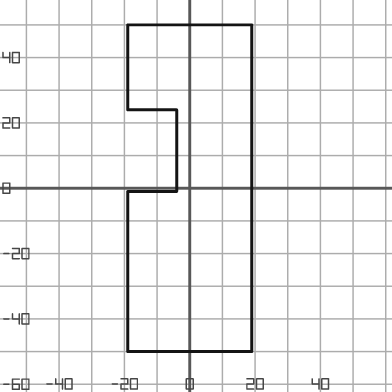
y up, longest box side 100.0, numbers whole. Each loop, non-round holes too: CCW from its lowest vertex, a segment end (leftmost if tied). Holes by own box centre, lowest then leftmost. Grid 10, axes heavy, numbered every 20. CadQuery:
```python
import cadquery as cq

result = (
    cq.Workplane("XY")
    .moveTo(-19.0, -50.0)
    .lineTo(19.0, -50.0)
    .lineTo(19.0, 50.0)
    .lineTo(-19.0, 50.0)
    .lineTo(-19.0, 24.0)
    .lineTo(-4.0, 24.0)
    .lineTo(-4.0, -1.0)
    .lineTo(-19.0, -1.0)
    .close()
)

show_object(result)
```